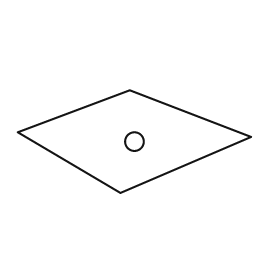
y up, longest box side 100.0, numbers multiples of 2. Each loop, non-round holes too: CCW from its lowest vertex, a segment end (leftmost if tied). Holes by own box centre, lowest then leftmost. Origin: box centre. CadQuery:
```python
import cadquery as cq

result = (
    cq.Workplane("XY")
    .moveTo(-6.0, -22.0)
    .lineTo(50.0, 2.0)
    .lineTo(-2.0, 22.0)
    .lineTo(-50.0, 4.0)
    .close()
    .moveTo(0.0, 0.0)
    .circle(4.0)
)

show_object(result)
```